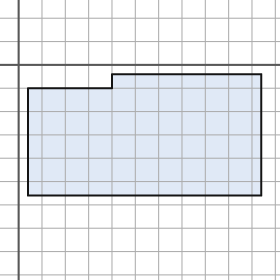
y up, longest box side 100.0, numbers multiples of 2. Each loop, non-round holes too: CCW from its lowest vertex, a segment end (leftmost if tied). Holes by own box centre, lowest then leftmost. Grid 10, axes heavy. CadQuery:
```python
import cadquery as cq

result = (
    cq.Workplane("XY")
    .moveTo(4.0, -56.0)
    .lineTo(104.0, -56.0)
    .lineTo(104.0, -4.0)
    .lineTo(40.0, -4.0)
    .lineTo(40.0, -10.0)
    .lineTo(4.0, -10.0)
    .close()
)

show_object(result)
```